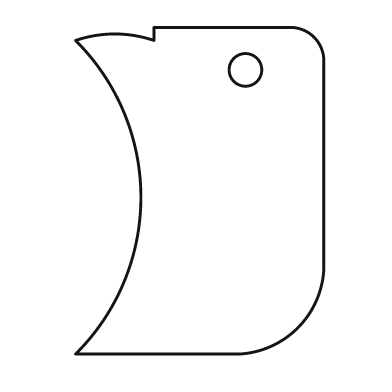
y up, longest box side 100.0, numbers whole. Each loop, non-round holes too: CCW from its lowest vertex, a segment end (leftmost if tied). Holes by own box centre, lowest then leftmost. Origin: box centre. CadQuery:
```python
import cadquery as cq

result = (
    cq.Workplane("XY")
    .moveTo(-38.0, -50.0)
    .lineTo(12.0, -50.0)
    .threePointArc((30.0, -42.0), (38.0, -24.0))
    .lineTo(38.0, 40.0)
    .threePointArc((35.0, 47.0), (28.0, 50.0))
    .lineTo(-14.0, 50.0)
    .lineTo(-14.0, 46.0)
    .threePointArc((-26.0, 48.0), (-38.0, 46.0))
    .threePointArc((-18.0, -2.0), (-38.0, -50.0))
    .close()
    .moveTo(14.0, 37.0)
    .circle(5.0)
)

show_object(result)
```